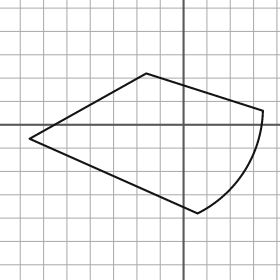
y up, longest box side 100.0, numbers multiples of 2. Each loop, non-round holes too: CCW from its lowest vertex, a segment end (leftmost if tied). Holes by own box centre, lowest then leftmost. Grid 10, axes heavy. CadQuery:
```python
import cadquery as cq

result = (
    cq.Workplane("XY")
    .moveTo(6.0, -38.0)
    .threePointArc((26.0, -20.0), (34.0, 6.0))
    .lineTo(-16.0, 22.0)
    .lineTo(-66.0, -6.0)
    .close()
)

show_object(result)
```